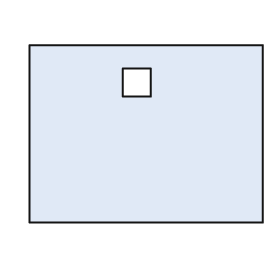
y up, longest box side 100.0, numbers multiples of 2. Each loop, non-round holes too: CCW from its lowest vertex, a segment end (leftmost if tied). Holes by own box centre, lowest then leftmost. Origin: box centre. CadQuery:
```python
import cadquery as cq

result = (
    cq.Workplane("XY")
    .moveTo(-50.0, -38.0)
    .lineTo(50.0, -38.0)
    .lineTo(50.0, 38.0)
    .lineTo(-50.0, 38.0)
    .close()
    .moveTo(-10.0, 16.0)
    .lineTo(2.0, 16.0)
    .lineTo(2.0, 28.0)
    .lineTo(-10.0, 28.0)
    .close()
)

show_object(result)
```